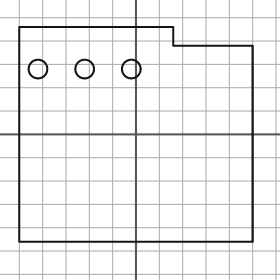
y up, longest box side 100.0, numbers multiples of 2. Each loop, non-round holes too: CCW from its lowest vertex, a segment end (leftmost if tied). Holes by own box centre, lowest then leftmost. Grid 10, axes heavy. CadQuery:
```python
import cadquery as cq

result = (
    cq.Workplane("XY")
    .moveTo(-50.0, -46.0)
    .lineTo(50.0, -46.0)
    .lineTo(50.0, 38.0)
    .lineTo(16.0, 38.0)
    .lineTo(16.0, 46.0)
    .lineTo(-50.0, 46.0)
    .close()
    .moveTo(-42.0, 28.0)
    .circle(4.0)
    .moveTo(-22.0, 28.0)
    .circle(4.0)
    .moveTo(-2.0, 28.0)
    .circle(4.0)
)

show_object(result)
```